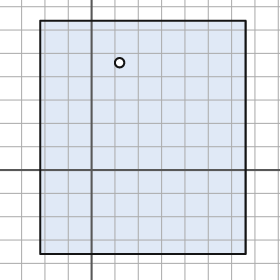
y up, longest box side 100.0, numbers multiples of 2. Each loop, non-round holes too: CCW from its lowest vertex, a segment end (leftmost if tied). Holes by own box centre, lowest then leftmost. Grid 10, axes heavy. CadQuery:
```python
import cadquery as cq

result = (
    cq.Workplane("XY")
    .moveTo(-22.0, -36.0)
    .lineTo(66.0, -36.0)
    .lineTo(66.0, 64.0)
    .lineTo(-22.0, 64.0)
    .close()
    .moveTo(12.0, 46.0)
    .circle(2.0)
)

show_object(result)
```